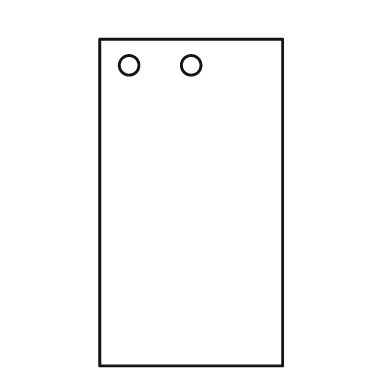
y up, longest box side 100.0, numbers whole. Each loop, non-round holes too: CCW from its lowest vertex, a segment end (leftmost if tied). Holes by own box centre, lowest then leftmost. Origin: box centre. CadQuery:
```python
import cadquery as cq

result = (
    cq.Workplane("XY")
    .moveTo(-28.0, -50.0)
    .lineTo(28.0, -50.0)
    .lineTo(28.0, 50.0)
    .lineTo(-28.0, 50.0)
    .close()
    .moveTo(-19.0, 42.0)
    .circle(3.0)
    .moveTo(0.0, 42.0)
    .circle(3.0)
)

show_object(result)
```